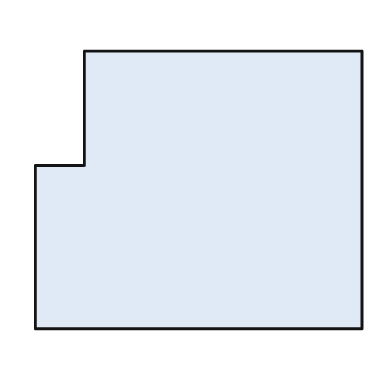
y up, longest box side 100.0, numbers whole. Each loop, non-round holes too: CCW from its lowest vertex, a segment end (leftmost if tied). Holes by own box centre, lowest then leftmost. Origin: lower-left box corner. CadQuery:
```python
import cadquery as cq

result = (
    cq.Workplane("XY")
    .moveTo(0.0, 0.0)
    .lineTo(100.0, 0.0)
    .lineTo(100.0, 85.0)
    .lineTo(15.0, 85.0)
    .lineTo(15.0, 50.0)
    .lineTo(0.0, 50.0)
    .close()
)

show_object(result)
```